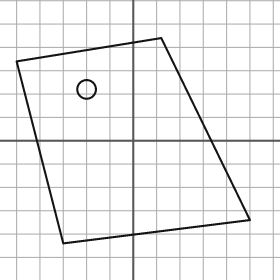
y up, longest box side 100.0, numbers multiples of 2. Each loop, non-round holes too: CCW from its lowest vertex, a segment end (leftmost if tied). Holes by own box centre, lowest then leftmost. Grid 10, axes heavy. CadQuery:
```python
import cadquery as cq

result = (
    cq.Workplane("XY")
    .moveTo(-30.0, -44.0)
    .lineTo(50.0, -34.0)
    .lineTo(12.0, 44.0)
    .lineTo(-50.0, 34.0)
    .close()
    .moveTo(-20.0, 22.0)
    .circle(4.0)
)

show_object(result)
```